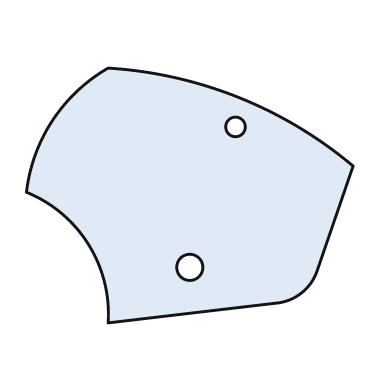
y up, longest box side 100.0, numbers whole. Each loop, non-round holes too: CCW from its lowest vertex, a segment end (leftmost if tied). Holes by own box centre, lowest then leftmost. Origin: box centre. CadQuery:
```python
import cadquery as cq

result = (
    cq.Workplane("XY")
    .moveTo(-25.0, -39.0)
    .lineTo(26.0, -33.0)
    .threePointArc((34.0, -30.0), (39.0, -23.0))
    .lineTo(50.0, 9.0)
    .threePointArc((15.0, 30.0), (-25.0, 39.0))
    .threePointArc((-42.0, 23.0), (-50.0, 1.0))
    .threePointArc((-31.0, -15.0), (-25.0, -39.0))
    .close()
    .moveTo(0.0, -22.0)
    .circle(4.0)
    .moveTo(14.0, 21.0)
    .circle(3.0)
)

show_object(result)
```